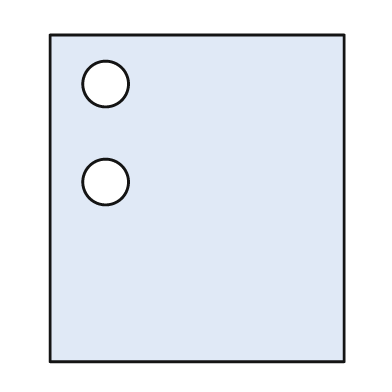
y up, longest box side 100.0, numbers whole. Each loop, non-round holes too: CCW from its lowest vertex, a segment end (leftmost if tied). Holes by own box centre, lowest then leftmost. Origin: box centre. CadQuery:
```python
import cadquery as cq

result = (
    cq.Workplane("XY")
    .moveTo(-45.0, -50.0)
    .lineTo(45.0, -50.0)
    .lineTo(45.0, 50.0)
    .lineTo(-45.0, 50.0)
    .close()
    .moveTo(-28.0, 5.0)
    .circle(7.0)
    .moveTo(-28.0, 35.0)
    .circle(7.0)
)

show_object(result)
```